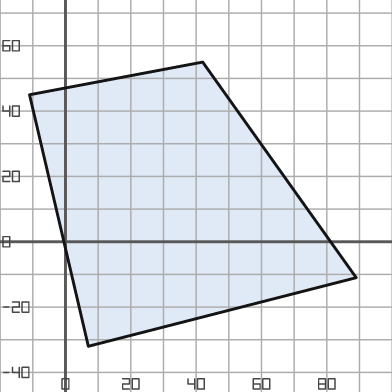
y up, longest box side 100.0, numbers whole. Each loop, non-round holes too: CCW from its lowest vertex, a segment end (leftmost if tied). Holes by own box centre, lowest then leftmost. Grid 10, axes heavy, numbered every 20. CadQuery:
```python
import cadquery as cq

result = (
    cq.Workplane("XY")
    .moveTo(7.0, -32.0)
    .lineTo(89.0, -11.0)
    .lineTo(42.0, 55.0)
    .lineTo(-11.0, 45.0)
    .close()
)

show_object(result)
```